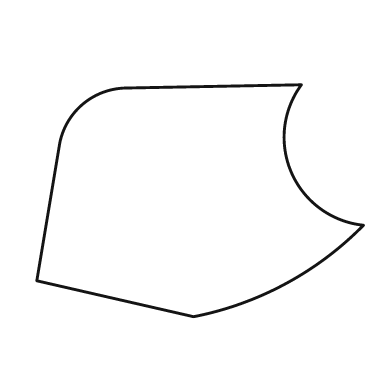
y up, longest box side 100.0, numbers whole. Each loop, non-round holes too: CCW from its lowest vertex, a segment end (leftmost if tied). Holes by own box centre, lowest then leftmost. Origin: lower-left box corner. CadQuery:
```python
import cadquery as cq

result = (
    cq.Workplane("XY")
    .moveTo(48.0, 0.0)
    .threePointArc((76.0, 10.0), (100.0, 28.0))
    .threePointArc((78.0, 44.0), (81.0, 71.0))
    .lineTo(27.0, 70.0)
    .threePointArc((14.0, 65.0), (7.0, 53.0))
    .lineTo(0.0, 11.0)
    .close()
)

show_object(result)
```